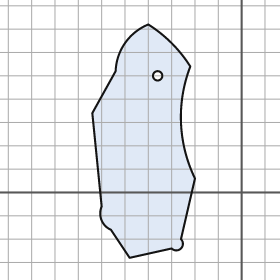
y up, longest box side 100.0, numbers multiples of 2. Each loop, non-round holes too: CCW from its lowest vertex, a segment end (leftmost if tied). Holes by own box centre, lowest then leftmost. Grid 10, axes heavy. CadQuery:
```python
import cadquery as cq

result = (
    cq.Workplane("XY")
    .moveTo(-48.0, -28.0)
    .lineTo(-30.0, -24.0)
    .threePointArc((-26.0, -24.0), (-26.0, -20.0))
    .lineTo(-20.0, 6.0)
    .threePointArc((-26.0, 30.0), (-22.0, 54.0))
    .threePointArc((-30.0, 64.0), (-40.0, 72.0))
    .threePointArc((-50.0, 64.0), (-54.0, 52.0))
    .lineTo(-64.0, 34.0)
    .lineTo(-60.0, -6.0)
    .threePointArc((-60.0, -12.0), (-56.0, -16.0))
    .close()
    .moveTo(-36.0, 50.0)
    .circle(2.0)
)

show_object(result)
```